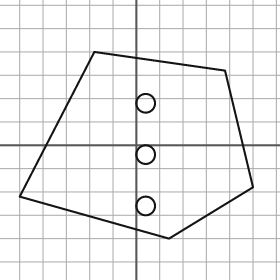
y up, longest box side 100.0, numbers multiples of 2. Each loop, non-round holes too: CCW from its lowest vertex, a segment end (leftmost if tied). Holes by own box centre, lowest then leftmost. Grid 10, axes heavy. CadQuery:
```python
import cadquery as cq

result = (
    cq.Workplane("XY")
    .moveTo(14.0, -40.0)
    .lineTo(50.0, -18.0)
    .lineTo(38.0, 32.0)
    .lineTo(-18.0, 40.0)
    .lineTo(-50.0, -22.0)
    .close()
    .moveTo(4.0, -26.0)
    .circle(4.0)
    .moveTo(4.0, -4.0)
    .circle(4.0)
    .moveTo(4.0, 18.0)
    .circle(4.0)
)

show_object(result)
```